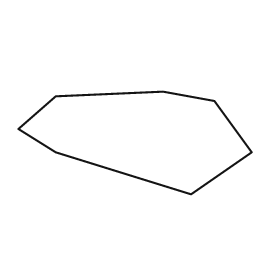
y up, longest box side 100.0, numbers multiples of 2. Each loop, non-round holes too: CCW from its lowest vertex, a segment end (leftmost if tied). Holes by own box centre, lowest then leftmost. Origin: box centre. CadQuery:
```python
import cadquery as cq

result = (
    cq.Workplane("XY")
    .moveTo(24.0, -22.0)
    .lineTo(50.0, -4.0)
    .lineTo(34.0, 18.0)
    .lineTo(12.0, 22.0)
    .lineTo(-34.0, 20.0)
    .lineTo(-50.0, 6.0)
    .lineTo(-34.0, -4.0)
    .close()
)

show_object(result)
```